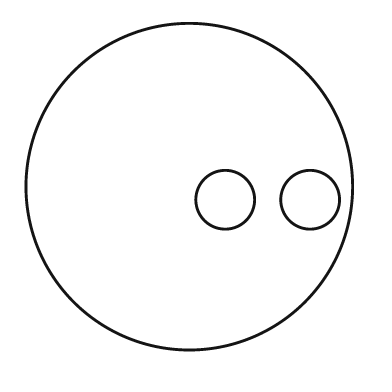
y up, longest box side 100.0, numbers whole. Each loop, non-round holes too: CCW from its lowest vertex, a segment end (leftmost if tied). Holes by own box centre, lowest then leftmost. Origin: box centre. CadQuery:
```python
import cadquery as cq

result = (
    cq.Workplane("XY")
    .moveTo(0.0, 0.0)
    .circle(50.0)
    .moveTo(11.0, -4.0)
    .circle(9.0)
    .moveTo(37.0, -4.0)
    .circle(9.0)
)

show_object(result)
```